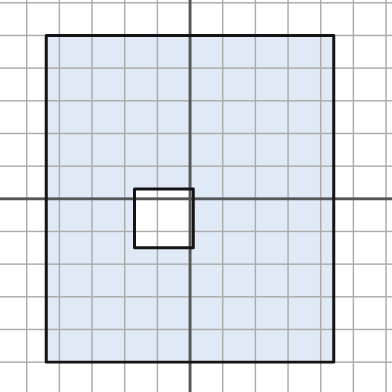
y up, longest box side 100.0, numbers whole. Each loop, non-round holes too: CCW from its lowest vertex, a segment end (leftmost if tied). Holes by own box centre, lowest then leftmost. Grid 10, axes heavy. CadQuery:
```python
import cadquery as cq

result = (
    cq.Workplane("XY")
    .moveTo(-44.0, -50.0)
    .lineTo(44.0, -50.0)
    .lineTo(44.0, 50.0)
    .lineTo(-44.0, 50.0)
    .close()
    .moveTo(-17.0, -15.0)
    .lineTo(1.0, -15.0)
    .lineTo(1.0, 3.0)
    .lineTo(-17.0, 3.0)
    .close()
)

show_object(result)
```